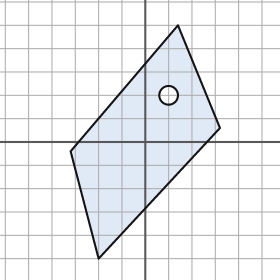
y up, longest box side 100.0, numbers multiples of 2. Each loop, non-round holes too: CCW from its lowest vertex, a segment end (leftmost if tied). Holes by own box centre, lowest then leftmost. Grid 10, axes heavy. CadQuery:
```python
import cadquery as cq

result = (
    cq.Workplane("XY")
    .moveTo(-20.0, -50.0)
    .lineTo(32.0, 6.0)
    .lineTo(14.0, 50.0)
    .lineTo(-32.0, -4.0)
    .close()
    .moveTo(10.0, 20.0)
    .circle(4.0)
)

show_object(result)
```